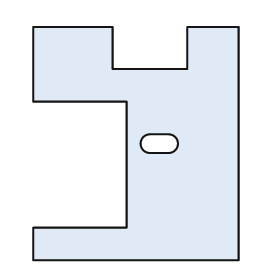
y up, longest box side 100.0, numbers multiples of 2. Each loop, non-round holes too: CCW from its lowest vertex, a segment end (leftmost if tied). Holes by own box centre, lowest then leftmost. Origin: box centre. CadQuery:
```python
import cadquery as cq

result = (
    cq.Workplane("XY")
    .moveTo(-44.0, -50.0)
    .lineTo(44.0, -50.0)
    .lineTo(44.0, 50.0)
    .lineTo(22.0, 50.0)
    .lineTo(22.0, 32.0)
    .lineTo(-10.0, 32.0)
    .lineTo(-10.0, 50.0)
    .lineTo(-44.0, 50.0)
    .lineTo(-44.0, 18.0)
    .lineTo(-4.0, 18.0)
    .lineTo(-4.0, -36.0)
    .lineTo(-44.0, -36.0)
    .close()
    .moveTo(6.0, -4.0)
    .lineTo(14.0, -4.0)
    .threePointArc((18.0, 0.0), (14.0, 4.0))
    .lineTo(6.0, 4.0)
    .threePointArc((2.0, 0.0), (6.0, -4.0))
    .close()
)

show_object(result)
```